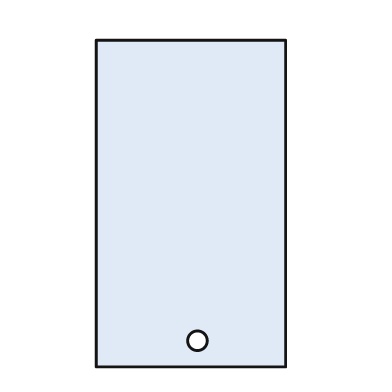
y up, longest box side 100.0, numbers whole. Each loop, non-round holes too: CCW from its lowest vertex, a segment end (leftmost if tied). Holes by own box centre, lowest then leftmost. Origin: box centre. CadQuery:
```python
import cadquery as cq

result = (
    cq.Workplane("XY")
    .moveTo(-29.0, -50.0)
    .lineTo(29.0, -50.0)
    .lineTo(29.0, 50.0)
    .lineTo(-29.0, 50.0)
    .close()
    .moveTo(2.0, -42.0)
    .circle(3.0)
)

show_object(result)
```